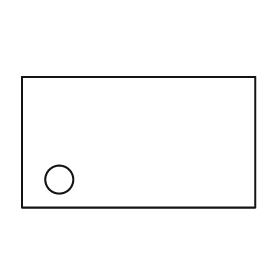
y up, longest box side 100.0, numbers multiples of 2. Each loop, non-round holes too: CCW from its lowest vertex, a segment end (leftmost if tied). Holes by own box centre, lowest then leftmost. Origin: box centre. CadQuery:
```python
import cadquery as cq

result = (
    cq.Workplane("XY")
    .moveTo(-50.0, -28.0)
    .lineTo(50.0, -28.0)
    .lineTo(50.0, 28.0)
    .lineTo(-50.0, 28.0)
    .close()
    .moveTo(-34.0, -16.0)
    .circle(6.0)
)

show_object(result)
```